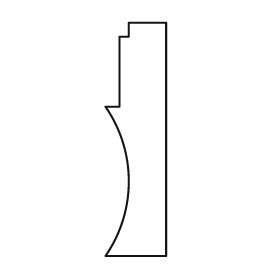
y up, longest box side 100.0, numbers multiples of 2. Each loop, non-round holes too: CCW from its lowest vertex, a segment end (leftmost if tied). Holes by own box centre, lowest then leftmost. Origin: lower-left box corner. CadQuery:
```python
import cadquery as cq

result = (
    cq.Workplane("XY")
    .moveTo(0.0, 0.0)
    .lineTo(26.0, 0.0)
    .lineTo(26.0, 100.0)
    .lineTo(10.0, 100.0)
    .lineTo(10.0, 94.0)
    .lineTo(6.0, 94.0)
    .lineTo(6.0, 64.0)
    .lineTo(0.0, 64.0)
    .threePointArc((10.0, 32.0), (0.0, 0.0))
    .close()
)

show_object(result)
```